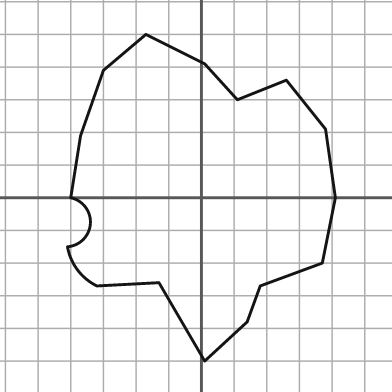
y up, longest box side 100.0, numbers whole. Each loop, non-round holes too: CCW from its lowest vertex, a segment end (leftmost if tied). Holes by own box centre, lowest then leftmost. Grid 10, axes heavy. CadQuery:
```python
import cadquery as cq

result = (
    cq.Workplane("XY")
    .moveTo(1.0, -50.0)
    .lineTo(14.0, -38.0)
    .lineTo(18.0, -27.0)
    .lineTo(37.0, -20.0)
    .lineTo(41.0, 0.0)
    .lineTo(38.0, 21.0)
    .lineTo(26.0, 36.0)
    .lineTo(11.0, 30.0)
    .lineTo(1.0, 41.0)
    .lineTo(-17.0, 50.0)
    .lineTo(-30.0, 39.0)
    .lineTo(-37.0, 19.0)
    .lineTo(-40.0, 0.0)
    .threePointArc((-34.0, -8.0), (-41.0, -15.0))
    .threePointArc((-38.0, -22.0), (-32.0, -27.0))
    .lineTo(-13.0, -26.0)
    .close()
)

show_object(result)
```